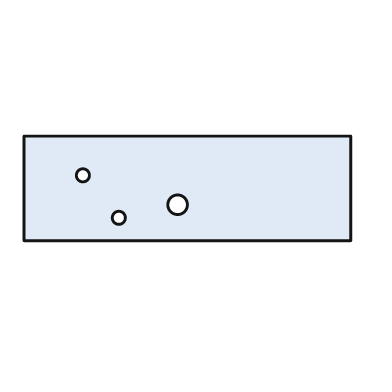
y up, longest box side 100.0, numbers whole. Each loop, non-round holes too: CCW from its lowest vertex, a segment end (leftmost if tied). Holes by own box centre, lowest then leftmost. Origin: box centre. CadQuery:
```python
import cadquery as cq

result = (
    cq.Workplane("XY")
    .moveTo(-50.0, -16.0)
    .lineTo(50.0, -16.0)
    .lineTo(50.0, 16.0)
    .lineTo(-50.0, 16.0)
    .close()
    .moveTo(-21.0, -9.0)
    .circle(2.0)
    .moveTo(-3.0, -5.0)
    .circle(3.0)
    .moveTo(-32.0, 4.0)
    .circle(2.0)
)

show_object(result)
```